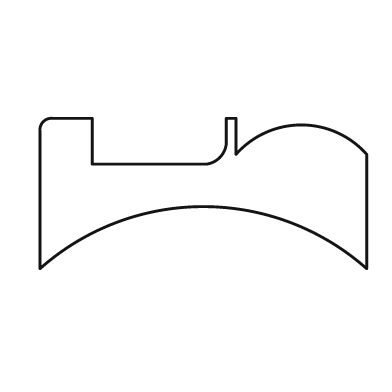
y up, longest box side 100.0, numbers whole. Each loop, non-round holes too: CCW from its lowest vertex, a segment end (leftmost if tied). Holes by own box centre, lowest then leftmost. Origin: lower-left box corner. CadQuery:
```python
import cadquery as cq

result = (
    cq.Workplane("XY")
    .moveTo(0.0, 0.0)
    .threePointArc((50.0, 19.0), (100.0, 0.0))
    .lineTo(100.0, 35.0)
    .threePointArc((80.0, 44.0), (60.0, 35.0))
    .lineTo(60.0, 46.0)
    .lineTo(57.0, 46.0)
    .lineTo(57.0, 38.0)
    .threePointArc((55.0, 34.0), (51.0, 32.0))
    .lineTo(16.0, 32.0)
    .lineTo(16.0, 46.0)
    .lineTo(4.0, 46.0)
    .threePointArc((1.0, 45.0), (0.0, 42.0))
    .close()
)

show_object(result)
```